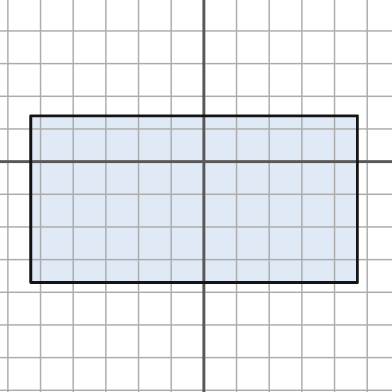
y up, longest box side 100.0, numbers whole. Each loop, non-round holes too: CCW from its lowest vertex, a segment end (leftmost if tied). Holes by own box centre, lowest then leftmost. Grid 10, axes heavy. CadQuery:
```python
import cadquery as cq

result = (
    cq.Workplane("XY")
    .moveTo(-53.0, -37.0)
    .lineTo(47.0, -37.0)
    .lineTo(47.0, 14.0)
    .lineTo(-53.0, 14.0)
    .close()
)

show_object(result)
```